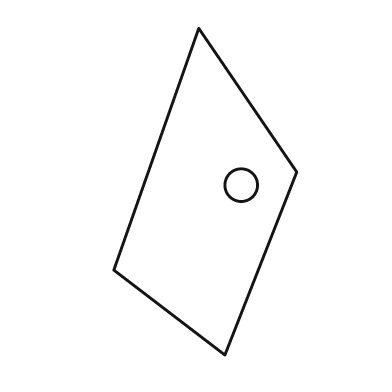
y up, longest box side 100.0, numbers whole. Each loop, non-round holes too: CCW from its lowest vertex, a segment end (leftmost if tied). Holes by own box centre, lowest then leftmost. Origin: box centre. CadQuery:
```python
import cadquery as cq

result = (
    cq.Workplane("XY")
    .moveTo(6.0, -50.0)
    .lineTo(28.0, 6.0)
    .lineTo(-2.0, 50.0)
    .lineTo(-28.0, -24.0)
    .close()
    .moveTo(11.0, 2.0)
    .circle(5.0)
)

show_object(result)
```